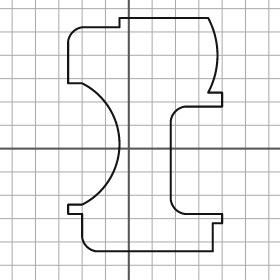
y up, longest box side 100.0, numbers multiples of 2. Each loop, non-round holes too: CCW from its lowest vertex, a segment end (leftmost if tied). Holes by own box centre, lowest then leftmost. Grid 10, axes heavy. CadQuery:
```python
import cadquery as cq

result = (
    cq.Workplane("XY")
    .moveTo(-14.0, -44.0)
    .lineTo(36.0, -44.0)
    .lineTo(36.0, -32.0)
    .lineTo(40.0, -32.0)
    .lineTo(40.0, -28.0)
    .lineTo(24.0, -28.0)
    .threePointArc((20.0, -26.0), (18.0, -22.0))
    .lineTo(18.0, 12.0)
    .threePointArc((20.0, 16.0), (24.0, 18.0))
    .lineTo(40.0, 18.0)
    .lineTo(40.0, 24.0)
    .lineTo(34.0, 24.0)
    .threePointArc((38.0, 40.0), (34.0, 56.0))
    .lineTo(-4.0, 56.0)
    .lineTo(-4.0, 52.0)
    .lineTo(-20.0, 52.0)
    .threePointArc((-24.0, 50.0), (-26.0, 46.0))
    .lineTo(-26.0, 28.0)
    .lineTo(-20.0, 28.0)
    .threePointArc((-4.0, 2.0), (-20.0, -24.0))
    .lineTo(-26.0, -24.0)
    .lineTo(-26.0, -28.0)
    .lineTo(-20.0, -28.0)
    .lineTo(-20.0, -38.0)
    .threePointArc((-18.0, -42.0), (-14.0, -44.0))
    .close()
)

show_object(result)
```